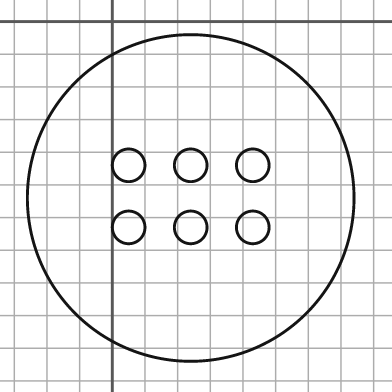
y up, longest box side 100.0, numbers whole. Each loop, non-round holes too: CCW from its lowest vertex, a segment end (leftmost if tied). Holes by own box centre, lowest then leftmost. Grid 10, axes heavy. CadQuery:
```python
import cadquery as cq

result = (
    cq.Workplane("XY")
    .moveTo(24.0, -54.0)
    .circle(50.0)
    .moveTo(5.0, -63.0)
    .circle(5.0)
    .moveTo(24.0, -63.0)
    .circle(5.0)
    .moveTo(43.0, -63.0)
    .circle(5.0)
    .moveTo(5.0, -44.0)
    .circle(5.0)
    .moveTo(24.0, -44.0)
    .circle(5.0)
    .moveTo(43.0, -44.0)
    .circle(5.0)
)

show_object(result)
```